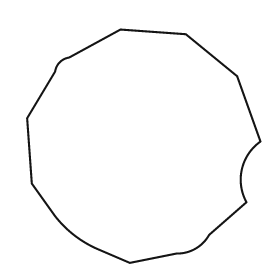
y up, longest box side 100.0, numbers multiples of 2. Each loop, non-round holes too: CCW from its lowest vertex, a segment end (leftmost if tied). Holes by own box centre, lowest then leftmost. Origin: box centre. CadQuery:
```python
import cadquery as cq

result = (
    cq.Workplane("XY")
    .moveTo(-6.0, -50.0)
    .lineTo(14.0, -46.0)
    .threePointArc((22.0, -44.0), (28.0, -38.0))
    .lineTo(44.0, -24.0)
    .threePointArc((42.0, -10.0), (50.0, 2.0))
    .lineTo(40.0, 30.0)
    .lineTo(18.0, 48.0)
    .lineTo(-10.0, 50.0)
    .lineTo(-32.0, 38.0)
    .threePointArc((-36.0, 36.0), (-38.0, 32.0))
    .lineTo(-50.0, 12.0)
    .lineTo(-48.0, -16.0)
    .lineTo(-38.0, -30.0)
    .threePointArc((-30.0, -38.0), (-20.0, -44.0))
    .close()
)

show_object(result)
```